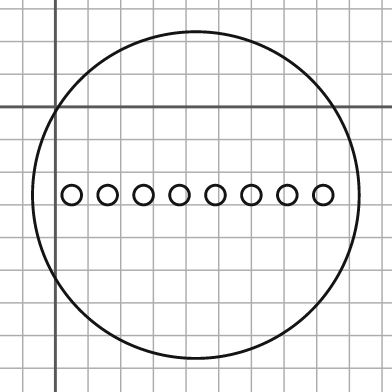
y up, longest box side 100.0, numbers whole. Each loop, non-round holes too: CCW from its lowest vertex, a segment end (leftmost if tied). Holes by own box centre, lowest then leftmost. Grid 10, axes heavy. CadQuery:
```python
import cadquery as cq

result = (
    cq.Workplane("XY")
    .moveTo(43.0, -27.0)
    .circle(50.0)
    .moveTo(5.0, -27.0)
    .circle(3.0)
    .moveTo(16.0, -27.0)
    .circle(3.0)
    .moveTo(27.0, -27.0)
    .circle(3.0)
    .moveTo(38.0, -27.0)
    .circle(3.0)
    .moveTo(49.0, -27.0)
    .circle(3.0)
    .moveTo(60.0, -27.0)
    .circle(3.0)
    .moveTo(71.0, -27.0)
    .circle(3.0)
    .moveTo(82.0, -27.0)
    .circle(3.0)
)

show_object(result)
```